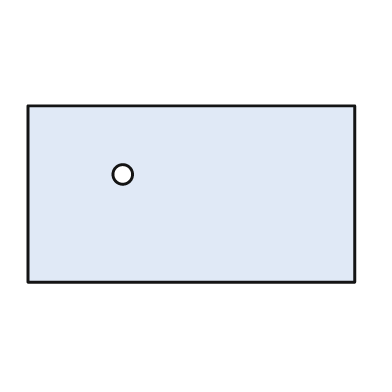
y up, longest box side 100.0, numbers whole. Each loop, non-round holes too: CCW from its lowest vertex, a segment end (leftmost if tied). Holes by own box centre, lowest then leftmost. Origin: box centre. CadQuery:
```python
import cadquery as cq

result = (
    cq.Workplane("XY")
    .moveTo(-50.0, -27.0)
    .lineTo(50.0, -27.0)
    .lineTo(50.0, 27.0)
    .lineTo(-50.0, 27.0)
    .close()
    .moveTo(-21.0, 6.0)
    .circle(3.0)
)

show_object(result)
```